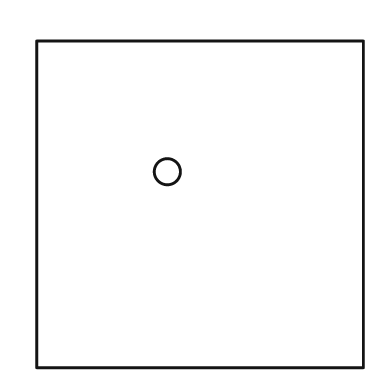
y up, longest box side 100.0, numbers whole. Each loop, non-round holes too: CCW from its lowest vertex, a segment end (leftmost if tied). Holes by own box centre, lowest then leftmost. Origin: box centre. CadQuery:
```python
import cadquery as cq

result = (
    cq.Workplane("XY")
    .moveTo(-50.0, -50.0)
    .lineTo(50.0, -50.0)
    .lineTo(50.0, 50.0)
    .lineTo(-50.0, 50.0)
    .close()
    .moveTo(-10.0, 10.0)
    .circle(4.0)
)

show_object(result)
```